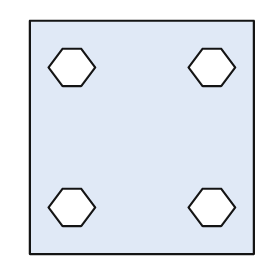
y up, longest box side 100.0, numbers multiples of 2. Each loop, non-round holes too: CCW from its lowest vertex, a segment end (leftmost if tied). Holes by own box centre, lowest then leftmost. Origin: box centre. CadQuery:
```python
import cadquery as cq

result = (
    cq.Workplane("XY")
    .moveTo(-48.0, -50.0)
    .lineTo(48.0, -50.0)
    .lineTo(48.0, 50.0)
    .lineTo(-48.0, 50.0)
    .close()
    .moveTo(-34.0, -38.0)
    .lineTo(-26.0, -38.0)
    .lineTo(-20.0, -30.0)
    .lineTo(-26.0, -22.0)
    .lineTo(-34.0, -22.0)
    .lineTo(-40.0, -30.0)
    .close()
    .moveTo(26.0, -38.0)
    .lineTo(34.0, -38.0)
    .lineTo(40.0, -30.0)
    .lineTo(34.0, -22.0)
    .lineTo(26.0, -22.0)
    .lineTo(20.0, -30.0)
    .close()
    .moveTo(-34.0, 22.0)
    .lineTo(-26.0, 22.0)
    .lineTo(-20.0, 30.0)
    .lineTo(-26.0, 38.0)
    .lineTo(-34.0, 38.0)
    .lineTo(-40.0, 30.0)
    .close()
    .moveTo(26.0, 22.0)
    .lineTo(34.0, 22.0)
    .lineTo(40.0, 30.0)
    .lineTo(34.0, 38.0)
    .lineTo(26.0, 38.0)
    .lineTo(20.0, 30.0)
    .close()
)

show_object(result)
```